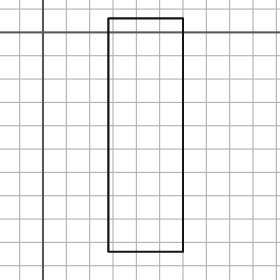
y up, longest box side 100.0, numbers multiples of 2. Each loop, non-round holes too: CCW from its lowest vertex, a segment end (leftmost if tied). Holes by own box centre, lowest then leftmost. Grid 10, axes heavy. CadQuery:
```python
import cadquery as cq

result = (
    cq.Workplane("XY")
    .moveTo(28.0, -94.0)
    .lineTo(60.0, -94.0)
    .lineTo(60.0, 6.0)
    .lineTo(28.0, 6.0)
    .close()
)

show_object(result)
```